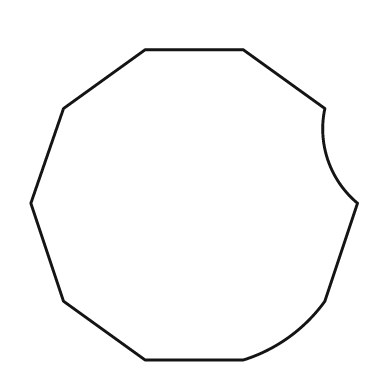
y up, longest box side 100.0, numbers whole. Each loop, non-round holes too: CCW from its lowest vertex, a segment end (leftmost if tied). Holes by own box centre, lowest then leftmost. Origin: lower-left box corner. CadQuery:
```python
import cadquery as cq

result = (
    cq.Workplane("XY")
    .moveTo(35.0, 0.0)
    .lineTo(65.0, 0.0)
    .threePointArc((79.0, 7.0), (90.0, 18.0))
    .lineTo(100.0, 48.0)
    .threePointArc((91.0, 61.0), (90.0, 77.0))
    .lineTo(65.0, 95.0)
    .lineTo(35.0, 95.0)
    .lineTo(10.0, 77.0)
    .lineTo(0.0, 48.0)
    .lineTo(10.0, 18.0)
    .close()
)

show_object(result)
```